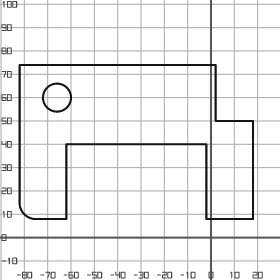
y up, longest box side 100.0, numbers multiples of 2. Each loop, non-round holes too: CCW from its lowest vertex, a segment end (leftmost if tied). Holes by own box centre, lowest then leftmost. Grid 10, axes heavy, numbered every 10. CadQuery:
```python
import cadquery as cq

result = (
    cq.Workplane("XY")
    .moveTo(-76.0, 8.0)
    .lineTo(-62.0, 8.0)
    .lineTo(-62.0, 40.0)
    .lineTo(-2.0, 40.0)
    .lineTo(-2.0, 8.0)
    .lineTo(18.0, 8.0)
    .lineTo(18.0, 50.0)
    .lineTo(2.0, 50.0)
    .lineTo(2.0, 74.0)
    .lineTo(-82.0, 74.0)
    .lineTo(-82.0, 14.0)
    .threePointArc((-80.0, 10.0), (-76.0, 8.0))
    .close()
    .moveTo(-66.0, 60.0)
    .circle(6.0)
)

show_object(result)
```